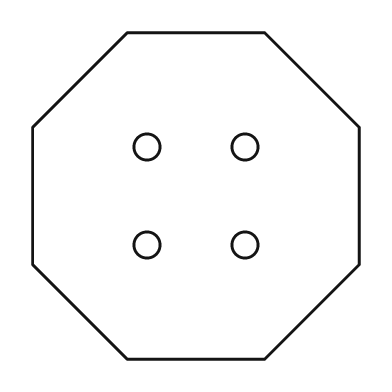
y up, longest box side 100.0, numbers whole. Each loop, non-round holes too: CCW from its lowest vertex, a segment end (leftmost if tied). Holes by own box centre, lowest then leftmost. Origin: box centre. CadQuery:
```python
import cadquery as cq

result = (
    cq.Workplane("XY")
    .moveTo(-21.0, -50.0)
    .lineTo(21.0, -50.0)
    .lineTo(50.0, -21.0)
    .lineTo(50.0, 21.0)
    .lineTo(21.0, 50.0)
    .lineTo(-21.0, 50.0)
    .lineTo(-50.0, 21.0)
    .lineTo(-50.0, -21.0)
    .close()
    .moveTo(-15.0, -15.0)
    .circle(4.0)
    .moveTo(15.0, -15.0)
    .circle(4.0)
    .moveTo(-15.0, 15.0)
    .circle(4.0)
    .moveTo(15.0, 15.0)
    .circle(4.0)
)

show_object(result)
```